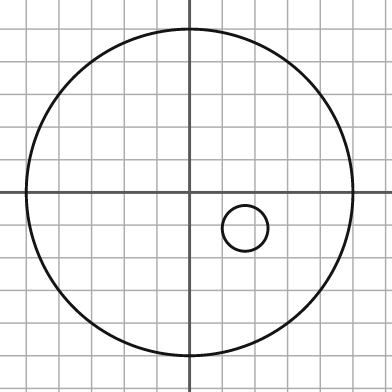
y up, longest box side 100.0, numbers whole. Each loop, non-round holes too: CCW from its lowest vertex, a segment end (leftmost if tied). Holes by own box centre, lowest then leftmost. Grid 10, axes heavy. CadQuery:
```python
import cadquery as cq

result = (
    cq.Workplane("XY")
    .moveTo(0.0, 0.0)
    .circle(50.0)
    .moveTo(17.0, -11.0)
    .circle(7.0)
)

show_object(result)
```